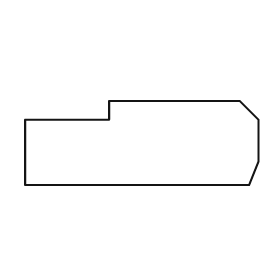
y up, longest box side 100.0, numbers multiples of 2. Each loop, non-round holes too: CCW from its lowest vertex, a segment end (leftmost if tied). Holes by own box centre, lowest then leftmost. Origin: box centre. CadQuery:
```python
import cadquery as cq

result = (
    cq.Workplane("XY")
    .moveTo(-50.0, -18.0)
    .lineTo(46.0, -18.0)
    .lineTo(50.0, -8.0)
    .lineTo(50.0, 10.0)
    .lineTo(42.0, 18.0)
    .lineTo(-14.0, 18.0)
    .lineTo(-14.0, 10.0)
    .lineTo(-50.0, 10.0)
    .close()
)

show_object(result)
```